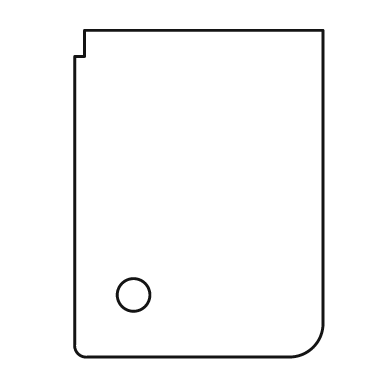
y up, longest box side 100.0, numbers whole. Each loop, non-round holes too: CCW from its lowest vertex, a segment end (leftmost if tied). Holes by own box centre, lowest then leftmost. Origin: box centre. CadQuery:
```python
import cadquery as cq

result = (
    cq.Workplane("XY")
    .moveTo(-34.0, -50.0)
    .lineTo(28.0, -50.0)
    .threePointArc((35.0, -47.0), (38.0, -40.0))
    .lineTo(38.0, 50.0)
    .lineTo(-35.0, 50.0)
    .lineTo(-35.0, 42.0)
    .lineTo(-38.0, 42.0)
    .lineTo(-38.0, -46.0)
    .threePointArc((-37.0, -49.0), (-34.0, -50.0))
    .close()
    .moveTo(-20.0, -31.0)
    .circle(5.0)
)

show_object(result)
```